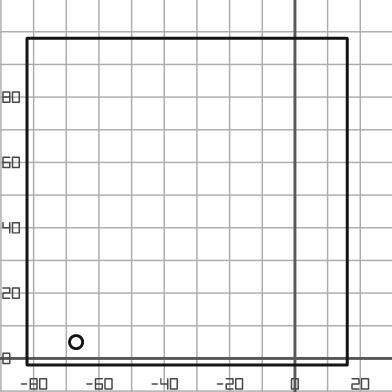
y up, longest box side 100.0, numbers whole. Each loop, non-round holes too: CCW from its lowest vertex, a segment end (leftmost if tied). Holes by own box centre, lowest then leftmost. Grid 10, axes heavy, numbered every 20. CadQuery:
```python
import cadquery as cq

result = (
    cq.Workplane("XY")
    .moveTo(-82.0, -2.0)
    .lineTo(16.0, -2.0)
    .lineTo(16.0, 98.0)
    .lineTo(-82.0, 98.0)
    .close()
    .moveTo(-67.0, 5.0)
    .circle(2.0)
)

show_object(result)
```